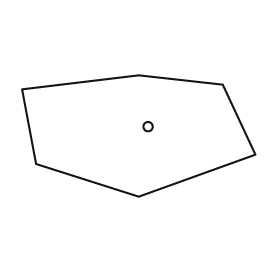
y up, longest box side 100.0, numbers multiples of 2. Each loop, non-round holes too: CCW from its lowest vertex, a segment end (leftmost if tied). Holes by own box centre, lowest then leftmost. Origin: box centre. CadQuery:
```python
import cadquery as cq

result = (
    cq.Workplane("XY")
    .moveTo(0.0, -26.0)
    .lineTo(50.0, -8.0)
    .lineTo(36.0, 22.0)
    .lineTo(0.0, 26.0)
    .lineTo(-50.0, 20.0)
    .lineTo(-44.0, -12.0)
    .close()
    .moveTo(4.0, 4.0)
    .circle(2.0)
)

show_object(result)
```